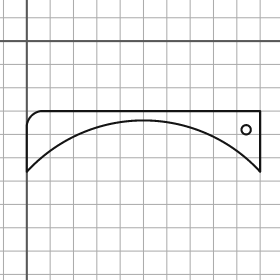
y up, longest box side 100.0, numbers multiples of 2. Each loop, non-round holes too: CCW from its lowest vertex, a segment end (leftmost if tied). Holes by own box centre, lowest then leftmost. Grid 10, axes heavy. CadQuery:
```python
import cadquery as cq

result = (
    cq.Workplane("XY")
    .moveTo(0.0, -56.0)
    .threePointArc((50.0, -34.0), (100.0, -56.0))
    .lineTo(100.0, -30.0)
    .lineTo(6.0, -30.0)
    .threePointArc((2.0, -32.0), (0.0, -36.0))
    .close()
    .moveTo(94.0, -38.0)
    .circle(2.0)
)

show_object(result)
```